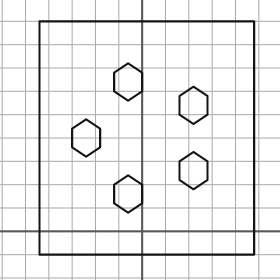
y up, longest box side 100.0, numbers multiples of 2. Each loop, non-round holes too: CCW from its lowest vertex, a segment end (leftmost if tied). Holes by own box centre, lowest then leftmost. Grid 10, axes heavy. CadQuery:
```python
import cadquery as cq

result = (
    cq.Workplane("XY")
    .moveTo(-44.0, -10.0)
    .lineTo(48.0, -10.0)
    .lineTo(48.0, 90.0)
    .lineTo(-44.0, 90.0)
    .close()
    .moveTo(-6.0, 8.0)
    .lineTo(0.0, 12.0)
    .lineTo(0.0, 20.0)
    .lineTo(-6.0, 24.0)
    .lineTo(-12.0, 20.0)
    .lineTo(-12.0, 12.0)
    .close()
    .moveTo(22.0, 18.0)
    .lineTo(28.0, 22.0)
    .lineTo(28.0, 30.0)
    .lineTo(22.0, 34.0)
    .lineTo(16.0, 30.0)
    .lineTo(16.0, 22.0)
    .close()
    .moveTo(-24.0, 32.0)
    .lineTo(-18.0, 36.0)
    .lineTo(-18.0, 44.0)
    .lineTo(-24.0, 48.0)
    .lineTo(-30.0, 44.0)
    .lineTo(-30.0, 36.0)
    .close()
    .moveTo(22.0, 46.0)
    .lineTo(28.0, 50.0)
    .lineTo(28.0, 58.0)
    .lineTo(22.0, 62.0)
    .lineTo(16.0, 58.0)
    .lineTo(16.0, 50.0)
    .close()
    .moveTo(-6.0, 56.0)
    .lineTo(0.0, 60.0)
    .lineTo(0.0, 68.0)
    .lineTo(-6.0, 72.0)
    .lineTo(-12.0, 68.0)
    .lineTo(-12.0, 60.0)
    .close()
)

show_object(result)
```